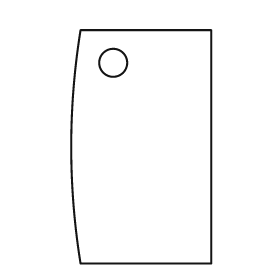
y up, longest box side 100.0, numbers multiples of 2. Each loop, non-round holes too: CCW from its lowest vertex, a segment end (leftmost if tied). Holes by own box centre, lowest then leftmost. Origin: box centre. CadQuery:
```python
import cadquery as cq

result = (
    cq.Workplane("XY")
    .moveTo(-26.0, -50.0)
    .lineTo(30.0, -50.0)
    .lineTo(30.0, 50.0)
    .lineTo(-26.0, 50.0)
    .threePointArc((-30.0, 0.0), (-26.0, -50.0))
    .close()
    .moveTo(-12.0, 36.0)
    .circle(6.0)
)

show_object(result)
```